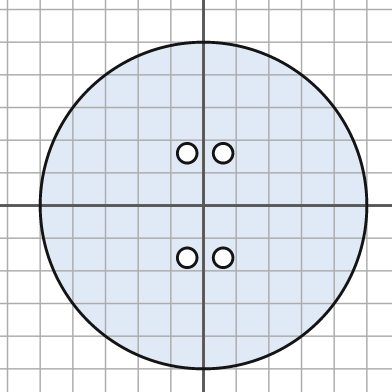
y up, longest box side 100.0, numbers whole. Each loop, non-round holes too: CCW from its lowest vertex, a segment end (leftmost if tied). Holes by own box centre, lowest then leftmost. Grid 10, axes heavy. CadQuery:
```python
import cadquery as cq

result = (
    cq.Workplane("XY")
    .moveTo(0.0, 0.0)
    .circle(50.0)
    .moveTo(-5.0, -16.0)
    .circle(3.0)
    .moveTo(6.0, -16.0)
    .circle(3.0)
    .moveTo(-5.0, 16.0)
    .circle(3.0)
    .moveTo(6.0, 16.0)
    .circle(3.0)
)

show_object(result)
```